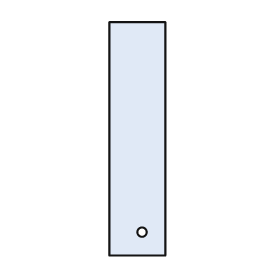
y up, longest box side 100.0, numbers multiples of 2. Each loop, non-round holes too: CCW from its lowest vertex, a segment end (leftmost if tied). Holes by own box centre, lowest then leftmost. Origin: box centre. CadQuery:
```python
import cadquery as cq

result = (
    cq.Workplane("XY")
    .moveTo(-12.0, -50.0)
    .lineTo(12.0, -50.0)
    .lineTo(12.0, 50.0)
    .lineTo(-12.0, 50.0)
    .close()
    .moveTo(2.0, -40.0)
    .circle(2.0)
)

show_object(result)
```